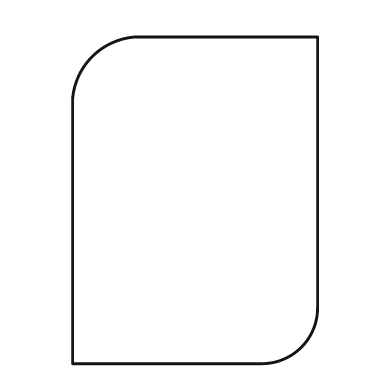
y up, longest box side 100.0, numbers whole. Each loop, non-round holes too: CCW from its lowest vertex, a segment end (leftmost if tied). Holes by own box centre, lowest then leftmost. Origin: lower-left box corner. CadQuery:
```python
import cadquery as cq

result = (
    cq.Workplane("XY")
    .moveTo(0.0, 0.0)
    .lineTo(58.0, 0.0)
    .threePointArc((70.0, 5.0), (75.0, 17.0))
    .lineTo(75.0, 100.0)
    .lineTo(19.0, 100.0)
    .threePointArc((6.0, 94.0), (0.0, 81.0))
    .close()
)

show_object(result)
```